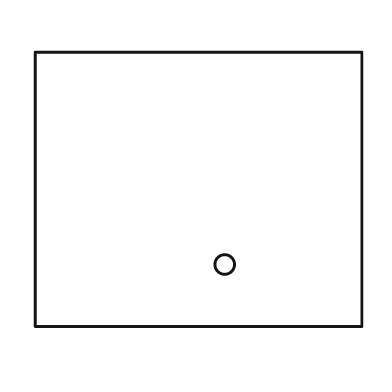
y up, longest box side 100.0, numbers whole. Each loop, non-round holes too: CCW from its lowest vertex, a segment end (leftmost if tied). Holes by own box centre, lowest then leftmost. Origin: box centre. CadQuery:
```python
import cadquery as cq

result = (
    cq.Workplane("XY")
    .moveTo(-50.0, -42.0)
    .lineTo(50.0, -42.0)
    .lineTo(50.0, 42.0)
    .lineTo(-50.0, 42.0)
    .close()
    .moveTo(8.0, -23.0)
    .circle(3.0)
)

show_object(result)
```